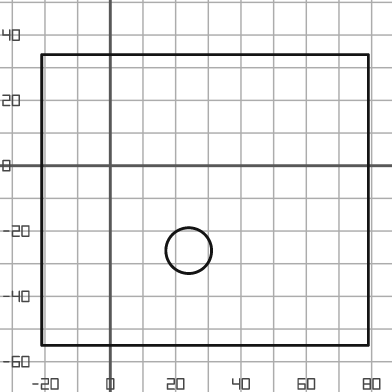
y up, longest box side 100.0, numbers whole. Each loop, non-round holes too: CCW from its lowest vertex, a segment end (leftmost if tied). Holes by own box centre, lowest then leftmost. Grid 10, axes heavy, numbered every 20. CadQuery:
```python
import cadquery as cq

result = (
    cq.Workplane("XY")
    .moveTo(-21.0, -55.0)
    .lineTo(79.0, -55.0)
    .lineTo(79.0, 34.0)
    .lineTo(-21.0, 34.0)
    .close()
    .moveTo(24.0, -26.0)
    .circle(7.0)
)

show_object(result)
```